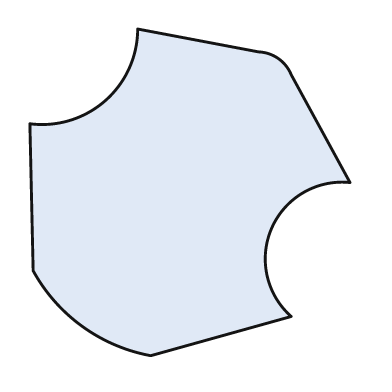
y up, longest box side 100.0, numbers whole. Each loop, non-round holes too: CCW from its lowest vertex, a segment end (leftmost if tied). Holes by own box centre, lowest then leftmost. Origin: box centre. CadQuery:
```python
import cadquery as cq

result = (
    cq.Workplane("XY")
    .moveTo(-12.0, -50.0)
    .lineTo(31.0, -38.0)
    .threePointArc((25.0, -11.0), (49.0, 3.0))
    .lineTo(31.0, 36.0)
    .threePointArc((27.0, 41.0), (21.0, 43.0))
    .lineTo(-16.0, 50.0)
    .threePointArc((-26.0, 28.0), (-49.0, 21.0))
    .lineTo(-48.0, -24.0)
    .threePointArc((-33.0, -41.0), (-12.0, -50.0))
    .close()
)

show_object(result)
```